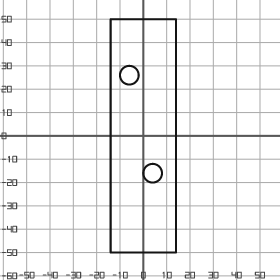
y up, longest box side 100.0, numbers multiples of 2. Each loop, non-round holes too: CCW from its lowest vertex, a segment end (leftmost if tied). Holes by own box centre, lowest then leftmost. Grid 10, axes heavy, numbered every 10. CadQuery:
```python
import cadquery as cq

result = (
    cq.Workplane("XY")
    .moveTo(-14.0, -50.0)
    .lineTo(14.0, -50.0)
    .lineTo(14.0, 50.0)
    .lineTo(-14.0, 50.0)
    .close()
    .moveTo(4.0, -16.0)
    .circle(4.0)
    .moveTo(-6.0, 26.0)
    .circle(4.0)
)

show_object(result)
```